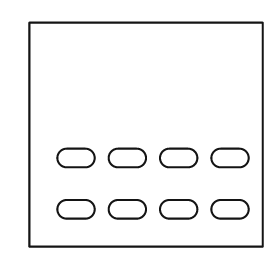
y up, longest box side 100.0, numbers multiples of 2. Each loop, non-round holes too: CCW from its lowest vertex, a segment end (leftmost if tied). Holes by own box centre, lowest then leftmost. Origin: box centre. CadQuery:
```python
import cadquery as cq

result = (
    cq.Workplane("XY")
    .moveTo(-50.0, -48.0)
    .lineTo(50.0, -48.0)
    .lineTo(50.0, 48.0)
    .lineTo(-50.0, 48.0)
    .close()
    .moveTo(-34.0, -36.0)
    .lineTo(-26.0, -36.0)
    .threePointArc((-22.0, -32.0), (-26.0, -28.0))
    .lineTo(-34.0, -28.0)
    .threePointArc((-38.0, -32.0), (-34.0, -36.0))
    .close()
    .moveTo(-12.0, -36.0)
    .lineTo(-4.0, -36.0)
    .threePointArc((0.0, -32.0), (-4.0, -28.0))
    .lineTo(-12.0, -28.0)
    .threePointArc((-16.0, -32.0), (-12.0, -36.0))
    .close()
    .moveTo(10.0, -36.0)
    .lineTo(18.0, -36.0)
    .threePointArc((22.0, -32.0), (18.0, -28.0))
    .lineTo(10.0, -28.0)
    .threePointArc((6.0, -32.0), (10.0, -36.0))
    .close()
    .moveTo(32.0, -36.0)
    .lineTo(40.0, -36.0)
    .threePointArc((44.0, -32.0), (40.0, -28.0))
    .lineTo(32.0, -28.0)
    .threePointArc((28.0, -32.0), (32.0, -36.0))
    .close()
    .moveTo(-34.0, -14.0)
    .lineTo(-26.0, -14.0)
    .threePointArc((-22.0, -10.0), (-26.0, -6.0))
    .lineTo(-34.0, -6.0)
    .threePointArc((-38.0, -10.0), (-34.0, -14.0))
    .close()
    .moveTo(-12.0, -14.0)
    .lineTo(-4.0, -14.0)
    .threePointArc((0.0, -10.0), (-4.0, -6.0))
    .lineTo(-12.0, -6.0)
    .threePointArc((-16.0, -10.0), (-12.0, -14.0))
    .close()
    .moveTo(10.0, -14.0)
    .lineTo(18.0, -14.0)
    .threePointArc((22.0, -10.0), (18.0, -6.0))
    .lineTo(10.0, -6.0)
    .threePointArc((6.0, -10.0), (10.0, -14.0))
    .close()
    .moveTo(32.0, -14.0)
    .lineTo(40.0, -14.0)
    .threePointArc((44.0, -10.0), (40.0, -6.0))
    .lineTo(32.0, -6.0)
    .threePointArc((28.0, -10.0), (32.0, -14.0))
    .close()
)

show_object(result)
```